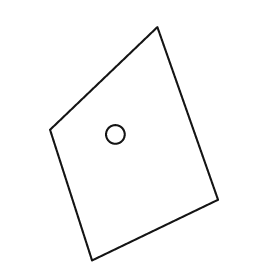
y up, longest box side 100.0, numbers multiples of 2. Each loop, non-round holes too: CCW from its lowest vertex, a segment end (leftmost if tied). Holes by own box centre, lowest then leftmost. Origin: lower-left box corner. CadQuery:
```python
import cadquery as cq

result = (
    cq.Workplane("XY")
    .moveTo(18.0, 0.0)
    .lineTo(72.0, 26.0)
    .lineTo(46.0, 100.0)
    .lineTo(0.0, 56.0)
    .close()
    .moveTo(28.0, 54.0)
    .circle(4.0)
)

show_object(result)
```